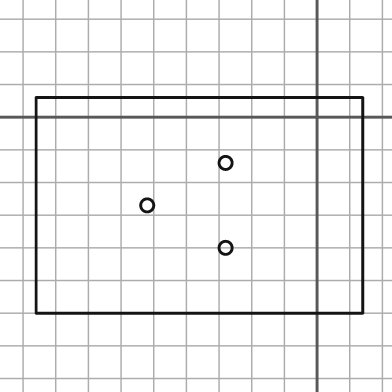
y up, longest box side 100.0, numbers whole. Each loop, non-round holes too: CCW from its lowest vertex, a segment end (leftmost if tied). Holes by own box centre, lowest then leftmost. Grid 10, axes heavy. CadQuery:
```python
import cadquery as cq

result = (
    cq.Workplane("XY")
    .moveTo(-86.0, -60.0)
    .lineTo(14.0, -60.0)
    .lineTo(14.0, 6.0)
    .lineTo(-86.0, 6.0)
    .close()
    .moveTo(-28.0, -40.0)
    .circle(2.0)
    .moveTo(-52.0, -27.0)
    .circle(2.0)
    .moveTo(-28.0, -14.0)
    .circle(2.0)
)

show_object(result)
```